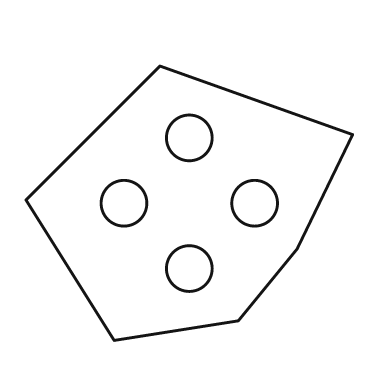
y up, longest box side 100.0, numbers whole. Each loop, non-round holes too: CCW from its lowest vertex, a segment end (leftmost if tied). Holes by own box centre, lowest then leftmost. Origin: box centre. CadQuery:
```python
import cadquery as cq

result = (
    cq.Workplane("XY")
    .moveTo(-23.0, -42.0)
    .lineTo(15.0, -36.0)
    .lineTo(33.0, -14.0)
    .lineTo(50.0, 21.0)
    .lineTo(-9.0, 42.0)
    .lineTo(-50.0, 1.0)
    .close()
    .moveTo(0.0, -20.0)
    .circle(7.0)
    .moveTo(-20.0, 0.0)
    .circle(7.0)
    .moveTo(20.0, 0.0)
    .circle(7.0)
    .moveTo(0.0, 20.0)
    .circle(7.0)
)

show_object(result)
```